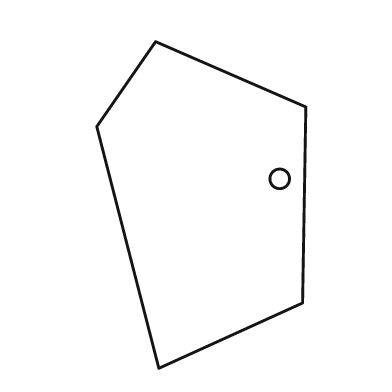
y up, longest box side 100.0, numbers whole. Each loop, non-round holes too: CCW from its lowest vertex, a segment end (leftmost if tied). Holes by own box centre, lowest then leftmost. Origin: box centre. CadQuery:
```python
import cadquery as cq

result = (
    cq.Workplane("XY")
    .moveTo(-13.0, -50.0)
    .lineTo(31.0, -30.0)
    .lineTo(32.0, 30.0)
    .lineTo(-14.0, 50.0)
    .lineTo(-32.0, 24.0)
    .close()
    .moveTo(24.0, 8.0)
    .circle(3.0)
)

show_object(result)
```